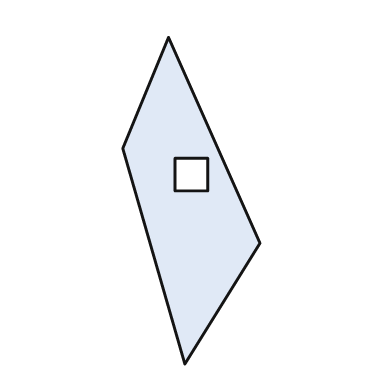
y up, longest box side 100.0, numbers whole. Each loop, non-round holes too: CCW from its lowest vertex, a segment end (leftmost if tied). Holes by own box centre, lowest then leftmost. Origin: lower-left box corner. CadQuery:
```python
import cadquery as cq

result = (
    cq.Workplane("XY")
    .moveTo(19.0, 0.0)
    .lineTo(42.0, 37.0)
    .lineTo(14.0, 100.0)
    .lineTo(0.0, 66.0)
    .close()
    .moveTo(16.0, 53.0)
    .lineTo(26.0, 53.0)
    .lineTo(26.0, 63.0)
    .lineTo(16.0, 63.0)
    .close()
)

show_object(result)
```